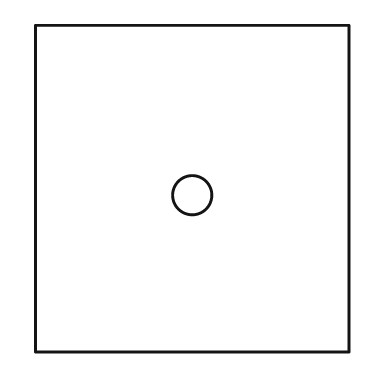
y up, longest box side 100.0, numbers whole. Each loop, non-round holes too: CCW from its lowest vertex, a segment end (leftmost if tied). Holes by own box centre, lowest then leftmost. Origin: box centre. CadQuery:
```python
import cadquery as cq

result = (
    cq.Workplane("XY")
    .moveTo(-48.0, -50.0)
    .lineTo(48.0, -50.0)
    .lineTo(48.0, 50.0)
    .lineTo(-48.0, 50.0)
    .close()
    .moveTo(0.0, -2.0)
    .circle(6.0)
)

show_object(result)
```